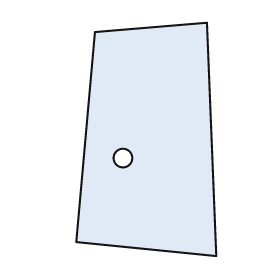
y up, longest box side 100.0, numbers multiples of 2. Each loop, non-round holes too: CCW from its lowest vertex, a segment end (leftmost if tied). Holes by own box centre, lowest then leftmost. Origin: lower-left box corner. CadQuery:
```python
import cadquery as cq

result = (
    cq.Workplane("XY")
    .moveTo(60.0, 0.0)
    .lineTo(56.0, 100.0)
    .lineTo(8.0, 96.0)
    .lineTo(0.0, 6.0)
    .close()
    .moveTo(20.0, 42.0)
    .circle(4.0)
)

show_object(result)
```